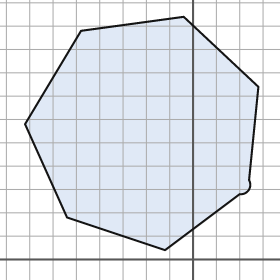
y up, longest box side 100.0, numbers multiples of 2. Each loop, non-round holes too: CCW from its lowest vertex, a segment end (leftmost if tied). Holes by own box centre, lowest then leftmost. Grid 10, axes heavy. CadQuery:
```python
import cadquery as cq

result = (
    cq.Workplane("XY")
    .moveTo(-12.0, 4.0)
    .lineTo(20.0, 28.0)
    .threePointArc((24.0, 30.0), (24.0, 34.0))
    .lineTo(28.0, 74.0)
    .lineTo(-4.0, 104.0)
    .lineTo(-48.0, 98.0)
    .lineTo(-72.0, 58.0)
    .lineTo(-54.0, 18.0)
    .close()
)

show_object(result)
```